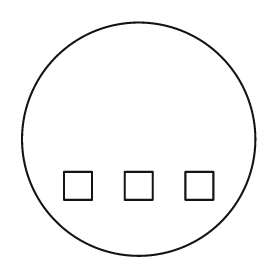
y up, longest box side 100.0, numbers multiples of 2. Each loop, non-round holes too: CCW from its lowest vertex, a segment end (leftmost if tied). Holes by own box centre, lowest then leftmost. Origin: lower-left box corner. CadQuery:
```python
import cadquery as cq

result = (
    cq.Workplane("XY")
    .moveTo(50.0, 50.0)
    .circle(50.0)
    .moveTo(18.0, 24.0)
    .lineTo(30.0, 24.0)
    .lineTo(30.0, 36.0)
    .lineTo(18.0, 36.0)
    .close()
    .moveTo(44.0, 24.0)
    .lineTo(56.0, 24.0)
    .lineTo(56.0, 36.0)
    .lineTo(44.0, 36.0)
    .close()
    .moveTo(70.0, 24.0)
    .lineTo(82.0, 24.0)
    .lineTo(82.0, 36.0)
    .lineTo(70.0, 36.0)
    .close()
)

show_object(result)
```